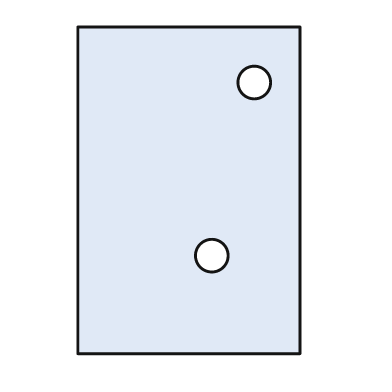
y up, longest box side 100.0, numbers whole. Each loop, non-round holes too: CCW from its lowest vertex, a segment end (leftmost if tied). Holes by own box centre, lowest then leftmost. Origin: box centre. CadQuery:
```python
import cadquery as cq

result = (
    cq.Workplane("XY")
    .moveTo(-34.0, -50.0)
    .lineTo(34.0, -50.0)
    .lineTo(34.0, 50.0)
    .lineTo(-34.0, 50.0)
    .close()
    .moveTo(7.0, -20.0)
    .circle(5.0)
    .moveTo(20.0, 33.0)
    .circle(5.0)
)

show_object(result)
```